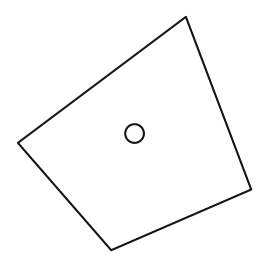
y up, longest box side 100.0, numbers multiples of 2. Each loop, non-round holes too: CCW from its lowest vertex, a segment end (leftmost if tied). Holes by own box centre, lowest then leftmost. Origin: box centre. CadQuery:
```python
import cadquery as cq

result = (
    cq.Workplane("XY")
    .moveTo(-10.0, -50.0)
    .lineTo(50.0, -24.0)
    .lineTo(22.0, 50.0)
    .lineTo(-50.0, -4.0)
    .close()
    .moveTo(0.0, 0.0)
    .circle(4.0)
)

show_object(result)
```